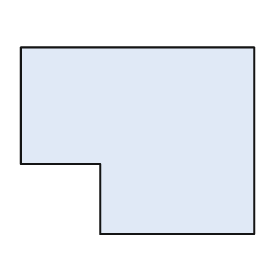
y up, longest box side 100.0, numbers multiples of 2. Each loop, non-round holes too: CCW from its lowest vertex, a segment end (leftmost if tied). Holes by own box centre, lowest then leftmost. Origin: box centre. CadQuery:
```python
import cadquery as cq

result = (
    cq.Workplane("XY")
    .moveTo(-16.0, -40.0)
    .lineTo(50.0, -40.0)
    .lineTo(50.0, 40.0)
    .lineTo(-50.0, 40.0)
    .lineTo(-50.0, -10.0)
    .lineTo(-16.0, -10.0)
    .close()
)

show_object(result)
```